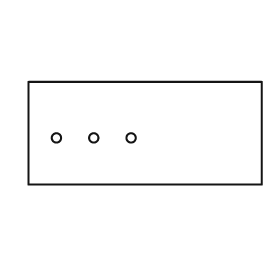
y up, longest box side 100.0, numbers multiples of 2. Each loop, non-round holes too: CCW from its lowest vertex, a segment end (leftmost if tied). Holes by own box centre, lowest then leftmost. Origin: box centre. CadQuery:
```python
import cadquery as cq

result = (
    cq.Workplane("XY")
    .moveTo(-50.0, -22.0)
    .lineTo(50.0, -22.0)
    .lineTo(50.0, 22.0)
    .lineTo(-50.0, 22.0)
    .close()
    .moveTo(-38.0, -2.0)
    .circle(2.0)
    .moveTo(-22.0, -2.0)
    .circle(2.0)
    .moveTo(-6.0, -2.0)
    .circle(2.0)
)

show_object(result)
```